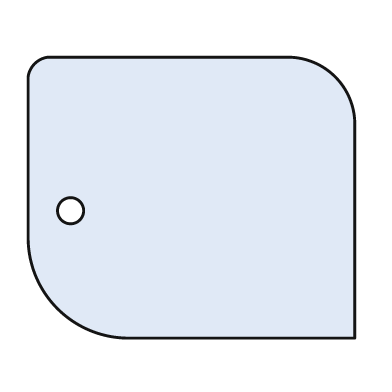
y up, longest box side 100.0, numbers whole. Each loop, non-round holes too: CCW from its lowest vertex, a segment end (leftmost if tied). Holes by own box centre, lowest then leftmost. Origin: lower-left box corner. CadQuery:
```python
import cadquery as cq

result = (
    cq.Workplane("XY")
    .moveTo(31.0, 0.0)
    .lineTo(100.0, 0.0)
    .lineTo(100.0, 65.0)
    .threePointArc((94.0, 80.0), (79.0, 86.0))
    .lineTo(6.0, 86.0)
    .threePointArc((2.0, 84.0), (0.0, 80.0))
    .lineTo(0.0, 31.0)
    .threePointArc((9.0, 9.0), (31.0, 0.0))
    .close()
    .moveTo(13.0, 39.0)
    .circle(4.0)
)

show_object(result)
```